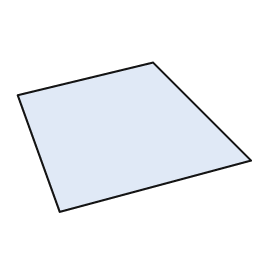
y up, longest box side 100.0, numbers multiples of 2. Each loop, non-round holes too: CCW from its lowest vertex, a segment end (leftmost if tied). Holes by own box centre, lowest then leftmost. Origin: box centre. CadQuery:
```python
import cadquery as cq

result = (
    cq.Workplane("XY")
    .moveTo(-32.0, -32.0)
    .lineTo(50.0, -10.0)
    .lineTo(8.0, 32.0)
    .lineTo(-50.0, 18.0)
    .close()
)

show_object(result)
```